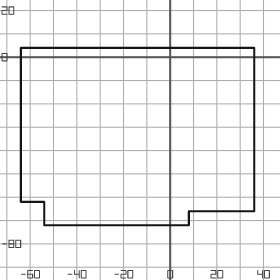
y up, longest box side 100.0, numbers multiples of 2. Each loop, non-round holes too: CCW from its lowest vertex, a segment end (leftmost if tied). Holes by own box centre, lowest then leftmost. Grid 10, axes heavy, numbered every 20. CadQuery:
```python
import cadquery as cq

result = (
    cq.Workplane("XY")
    .moveTo(-54.0, -72.0)
    .lineTo(8.0, -72.0)
    .lineTo(8.0, -66.0)
    .lineTo(36.0, -66.0)
    .lineTo(36.0, 4.0)
    .lineTo(-64.0, 4.0)
    .lineTo(-64.0, -62.0)
    .lineTo(-54.0, -62.0)
    .close()
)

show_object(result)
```